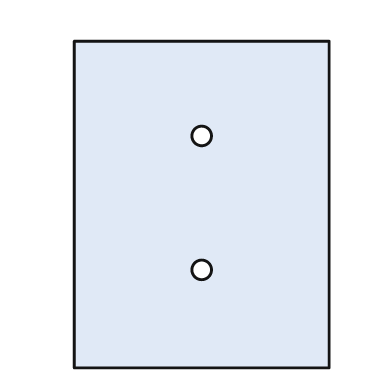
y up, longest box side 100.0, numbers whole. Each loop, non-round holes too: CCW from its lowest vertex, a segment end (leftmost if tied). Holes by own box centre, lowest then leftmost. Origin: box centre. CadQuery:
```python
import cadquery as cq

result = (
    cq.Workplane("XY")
    .moveTo(-39.0, -50.0)
    .lineTo(39.0, -50.0)
    .lineTo(39.0, 50.0)
    .lineTo(-39.0, 50.0)
    .close()
    .moveTo(0.0, -20.0)
    .circle(3.0)
    .moveTo(0.0, 21.0)
    .circle(3.0)
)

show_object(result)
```